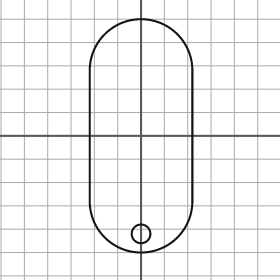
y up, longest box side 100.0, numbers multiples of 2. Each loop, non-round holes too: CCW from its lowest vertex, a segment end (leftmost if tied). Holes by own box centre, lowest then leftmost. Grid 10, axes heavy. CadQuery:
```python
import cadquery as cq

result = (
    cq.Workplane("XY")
    .moveTo(-22.0, -28.0)
    .threePointArc((0.0, -50.0), (22.0, -28.0))
    .lineTo(22.0, 28.0)
    .threePointArc((0.0, 50.0), (-22.0, 28.0))
    .close()
    .moveTo(0.0, -42.0)
    .circle(4.0)
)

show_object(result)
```